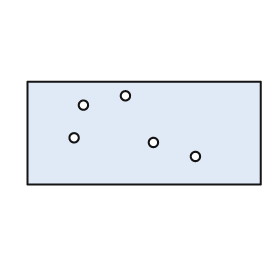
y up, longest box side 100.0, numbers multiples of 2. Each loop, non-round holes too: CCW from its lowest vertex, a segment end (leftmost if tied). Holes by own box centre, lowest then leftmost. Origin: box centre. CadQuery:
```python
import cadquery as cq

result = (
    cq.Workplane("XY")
    .moveTo(-50.0, -22.0)
    .lineTo(50.0, -22.0)
    .lineTo(50.0, 22.0)
    .lineTo(-50.0, 22.0)
    .close()
    .moveTo(22.0, -10.0)
    .circle(2.0)
    .moveTo(4.0, -4.0)
    .circle(2.0)
    .moveTo(-30.0, -2.0)
    .circle(2.0)
    .moveTo(-26.0, 12.0)
    .circle(2.0)
    .moveTo(-8.0, 16.0)
    .circle(2.0)
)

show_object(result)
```